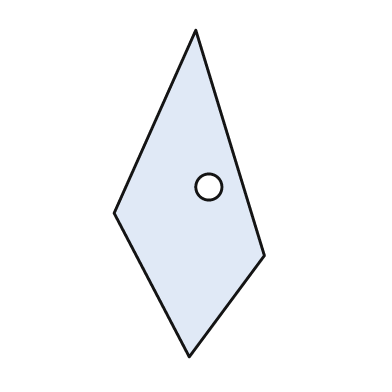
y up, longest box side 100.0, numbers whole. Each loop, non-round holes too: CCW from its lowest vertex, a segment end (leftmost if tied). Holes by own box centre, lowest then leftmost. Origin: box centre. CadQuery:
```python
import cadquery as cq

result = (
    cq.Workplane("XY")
    .moveTo(0.0, -50.0)
    .lineTo(23.0, -19.0)
    .lineTo(2.0, 50.0)
    .lineTo(-23.0, -6.0)
    .close()
    .moveTo(6.0, 2.0)
    .circle(4.0)
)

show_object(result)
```